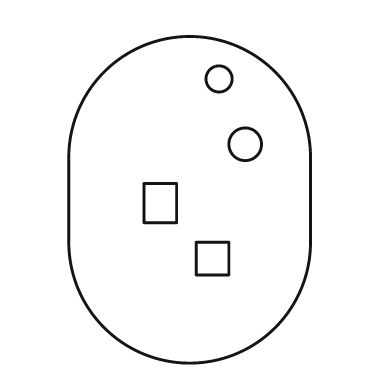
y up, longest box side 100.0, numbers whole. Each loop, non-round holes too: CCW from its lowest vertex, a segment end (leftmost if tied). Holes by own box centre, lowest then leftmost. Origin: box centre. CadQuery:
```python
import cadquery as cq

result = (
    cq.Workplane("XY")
    .moveTo(-37.0, -13.0)
    .threePointArc((0.0, -50.0), (37.0, -13.0))
    .lineTo(37.0, 13.0)
    .threePointArc((0.0, 50.0), (-37.0, 13.0))
    .close()
    .moveTo(2.0, -23.0)
    .lineTo(12.0, -23.0)
    .lineTo(12.0, -13.0)
    .lineTo(2.0, -13.0)
    .close()
    .moveTo(-14.0, -7.0)
    .lineTo(-4.0, -7.0)
    .lineTo(-4.0, 5.0)
    .lineTo(-14.0, 5.0)
    .close()
    .moveTo(17.0, 17.0)
    .circle(5.0)
    .moveTo(9.0, 37.0)
    .circle(4.0)
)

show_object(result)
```